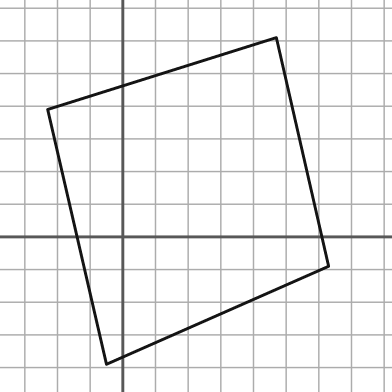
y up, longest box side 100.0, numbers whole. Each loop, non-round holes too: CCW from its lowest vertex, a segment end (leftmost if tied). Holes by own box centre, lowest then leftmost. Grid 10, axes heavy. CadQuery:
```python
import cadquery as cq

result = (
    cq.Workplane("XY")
    .moveTo(-5.0, -39.0)
    .lineTo(63.0, -9.0)
    .lineTo(47.0, 61.0)
    .lineTo(-23.0, 39.0)
    .close()
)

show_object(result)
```